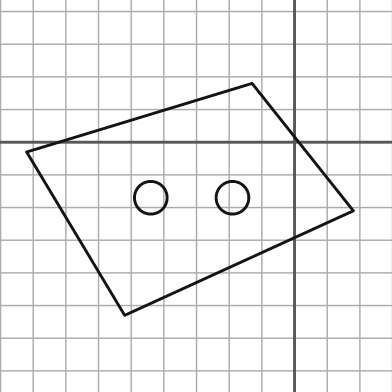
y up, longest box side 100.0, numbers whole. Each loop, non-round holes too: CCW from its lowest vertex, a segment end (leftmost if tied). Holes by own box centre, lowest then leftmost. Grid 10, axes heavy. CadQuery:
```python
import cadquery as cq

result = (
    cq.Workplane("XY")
    .moveTo(-52.0, -53.0)
    .lineTo(18.0, -21.0)
    .lineTo(-13.0, 18.0)
    .lineTo(-82.0, -3.0)
    .close()
    .moveTo(-44.0, -17.0)
    .circle(5.0)
    .moveTo(-19.0, -17.0)
    .circle(5.0)
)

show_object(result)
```